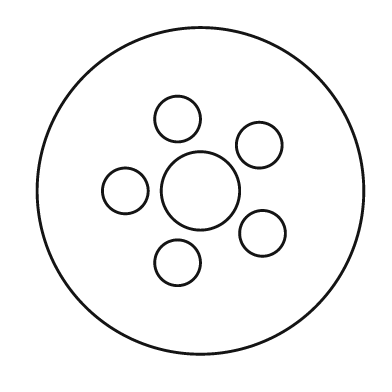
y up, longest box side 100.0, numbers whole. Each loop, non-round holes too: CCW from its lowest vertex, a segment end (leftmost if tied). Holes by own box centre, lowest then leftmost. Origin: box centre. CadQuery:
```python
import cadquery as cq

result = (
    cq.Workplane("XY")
    .moveTo(0.0, 0.0)
    .circle(50.0)
    .moveTo(-7.0, -22.0)
    .circle(7.0)
    .moveTo(19.0, -13.0)
    .circle(7.0)
    .moveTo(-23.0, 0.0)
    .circle(7.0)
    .moveTo(0.0, 0.0)
    .circle(12.0)
    .moveTo(18.0, 14.0)
    .circle(7.0)
    .moveTo(-7.0, 22.0)
    .circle(7.0)
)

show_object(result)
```